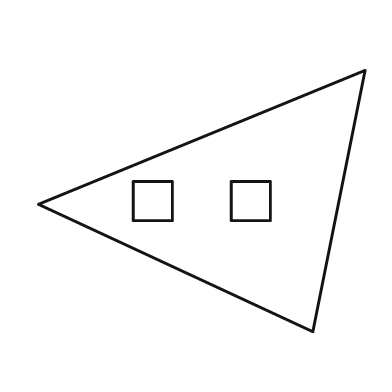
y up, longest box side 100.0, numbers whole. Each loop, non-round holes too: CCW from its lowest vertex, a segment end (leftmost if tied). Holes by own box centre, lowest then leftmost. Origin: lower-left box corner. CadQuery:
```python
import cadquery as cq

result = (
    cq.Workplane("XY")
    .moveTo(84.0, 0.0)
    .lineTo(100.0, 80.0)
    .lineTo(0.0, 39.0)
    .close()
    .moveTo(29.0, 34.0)
    .lineTo(41.0, 34.0)
    .lineTo(41.0, 46.0)
    .lineTo(29.0, 46.0)
    .close()
    .moveTo(59.0, 34.0)
    .lineTo(71.0, 34.0)
    .lineTo(71.0, 46.0)
    .lineTo(59.0, 46.0)
    .close()
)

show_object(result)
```